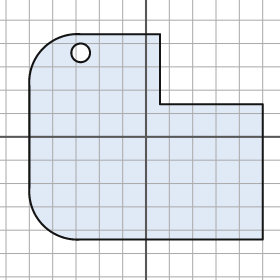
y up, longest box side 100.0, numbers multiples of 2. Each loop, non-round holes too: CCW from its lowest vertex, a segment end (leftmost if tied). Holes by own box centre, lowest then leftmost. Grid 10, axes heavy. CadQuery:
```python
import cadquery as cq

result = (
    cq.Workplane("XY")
    .moveTo(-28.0, -44.0)
    .lineTo(50.0, -44.0)
    .lineTo(50.0, 14.0)
    .lineTo(6.0, 14.0)
    .lineTo(6.0, 44.0)
    .lineTo(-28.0, 44.0)
    .threePointArc((-44.0, 38.0), (-50.0, 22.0))
    .lineTo(-50.0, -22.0)
    .threePointArc((-44.0, -38.0), (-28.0, -44.0))
    .close()
    .moveTo(-28.0, 36.0)
    .circle(4.0)
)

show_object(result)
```